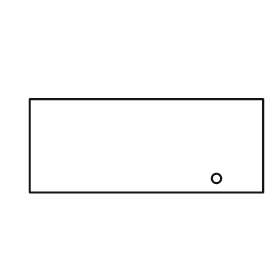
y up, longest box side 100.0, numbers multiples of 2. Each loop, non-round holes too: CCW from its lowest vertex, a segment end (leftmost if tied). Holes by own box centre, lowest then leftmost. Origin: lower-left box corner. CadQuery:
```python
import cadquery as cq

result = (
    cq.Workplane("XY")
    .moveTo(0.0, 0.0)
    .lineTo(100.0, 0.0)
    .lineTo(100.0, 40.0)
    .lineTo(0.0, 40.0)
    .close()
    .moveTo(80.0, 6.0)
    .circle(2.0)
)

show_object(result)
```